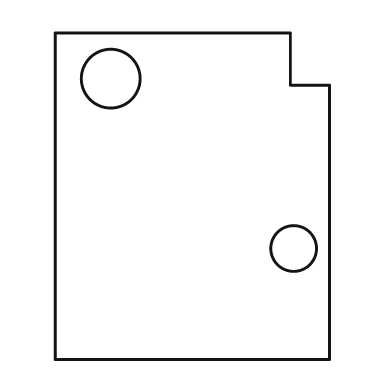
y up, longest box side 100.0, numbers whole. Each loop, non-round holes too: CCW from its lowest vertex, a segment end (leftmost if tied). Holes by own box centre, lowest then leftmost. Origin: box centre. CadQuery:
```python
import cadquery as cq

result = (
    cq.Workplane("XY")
    .moveTo(-42.0, -50.0)
    .lineTo(42.0, -50.0)
    .lineTo(42.0, 34.0)
    .lineTo(30.0, 34.0)
    .lineTo(30.0, 50.0)
    .lineTo(-42.0, 50.0)
    .close()
    .moveTo(31.0, -16.0)
    .circle(7.0)
    .moveTo(-25.0, 36.0)
    .circle(9.0)
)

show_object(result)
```